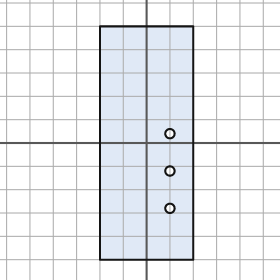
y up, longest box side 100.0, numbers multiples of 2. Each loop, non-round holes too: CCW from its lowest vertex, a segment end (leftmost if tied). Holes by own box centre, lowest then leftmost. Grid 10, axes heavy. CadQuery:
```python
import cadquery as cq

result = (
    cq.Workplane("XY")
    .moveTo(-20.0, -50.0)
    .lineTo(20.0, -50.0)
    .lineTo(20.0, 50.0)
    .lineTo(-20.0, 50.0)
    .close()
    .moveTo(10.0, -28.0)
    .circle(2.0)
    .moveTo(10.0, -12.0)
    .circle(2.0)
    .moveTo(10.0, 4.0)
    .circle(2.0)
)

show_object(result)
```